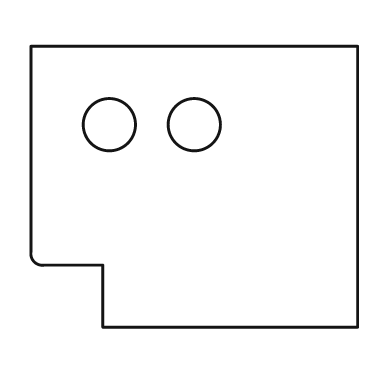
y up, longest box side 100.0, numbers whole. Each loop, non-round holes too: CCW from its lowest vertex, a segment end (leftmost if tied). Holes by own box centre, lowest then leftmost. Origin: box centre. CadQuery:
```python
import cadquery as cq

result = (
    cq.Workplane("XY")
    .moveTo(-28.0, -43.0)
    .lineTo(50.0, -43.0)
    .lineTo(50.0, 43.0)
    .lineTo(-50.0, 43.0)
    .lineTo(-50.0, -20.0)
    .threePointArc((-49.0, -23.0), (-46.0, -24.0))
    .lineTo(-28.0, -24.0)
    .close()
    .moveTo(-26.0, 19.0)
    .circle(8.0)
    .moveTo(0.0, 19.0)
    .circle(8.0)
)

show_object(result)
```